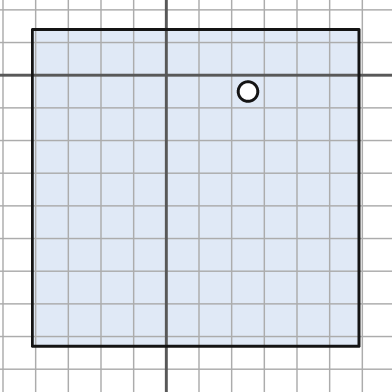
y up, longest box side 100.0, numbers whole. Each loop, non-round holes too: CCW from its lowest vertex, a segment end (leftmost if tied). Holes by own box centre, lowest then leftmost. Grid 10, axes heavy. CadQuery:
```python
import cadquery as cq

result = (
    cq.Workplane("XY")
    .moveTo(-41.0, -83.0)
    .lineTo(59.0, -83.0)
    .lineTo(59.0, 14.0)
    .lineTo(-41.0, 14.0)
    .close()
    .moveTo(25.0, -5.0)
    .circle(3.0)
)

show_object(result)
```